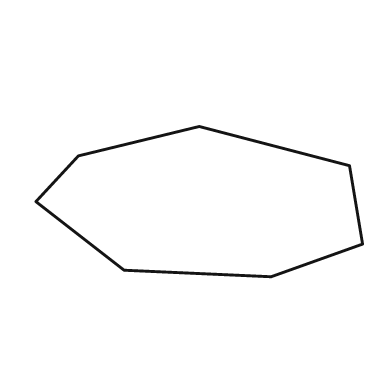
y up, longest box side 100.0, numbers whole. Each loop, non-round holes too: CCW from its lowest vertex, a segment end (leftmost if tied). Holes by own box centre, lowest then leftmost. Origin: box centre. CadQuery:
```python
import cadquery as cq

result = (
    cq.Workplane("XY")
    .moveTo(22.0, -23.0)
    .lineTo(50.0, -13.0)
    .lineTo(46.0, 11.0)
    .lineTo(0.0, 23.0)
    .lineTo(-37.0, 14.0)
    .lineTo(-50.0, 0.0)
    .lineTo(-23.0, -21.0)
    .close()
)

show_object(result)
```